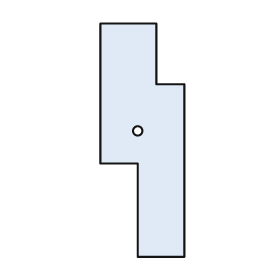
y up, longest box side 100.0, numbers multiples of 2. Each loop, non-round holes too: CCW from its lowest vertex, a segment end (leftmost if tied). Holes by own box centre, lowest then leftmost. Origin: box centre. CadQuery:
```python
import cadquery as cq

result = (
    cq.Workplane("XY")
    .moveTo(-2.0, -50.0)
    .lineTo(18.0, -50.0)
    .lineTo(18.0, 24.0)
    .lineTo(6.0, 24.0)
    .lineTo(6.0, 50.0)
    .lineTo(-18.0, 50.0)
    .lineTo(-18.0, -10.0)
    .lineTo(-2.0, -10.0)
    .close()
    .moveTo(-2.0, 4.0)
    .circle(2.0)
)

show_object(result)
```